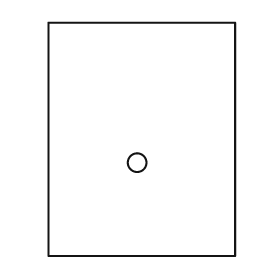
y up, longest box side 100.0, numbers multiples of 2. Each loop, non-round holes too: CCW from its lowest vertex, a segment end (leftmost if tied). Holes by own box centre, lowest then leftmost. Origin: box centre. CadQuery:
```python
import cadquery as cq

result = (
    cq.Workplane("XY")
    .moveTo(-40.0, -50.0)
    .lineTo(40.0, -50.0)
    .lineTo(40.0, 50.0)
    .lineTo(-40.0, 50.0)
    .close()
    .moveTo(-2.0, -10.0)
    .circle(4.0)
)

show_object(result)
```